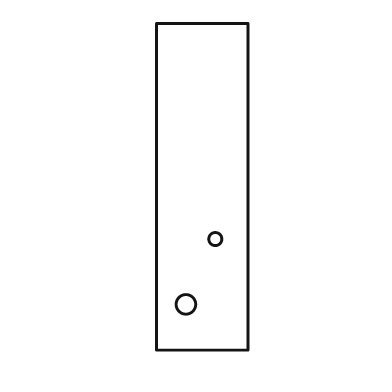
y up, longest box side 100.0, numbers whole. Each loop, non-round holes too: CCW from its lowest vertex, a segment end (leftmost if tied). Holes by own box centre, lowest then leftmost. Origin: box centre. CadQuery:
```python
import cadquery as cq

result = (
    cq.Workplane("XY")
    .moveTo(-14.0, -50.0)
    .lineTo(14.0, -50.0)
    .lineTo(14.0, 50.0)
    .lineTo(-14.0, 50.0)
    .close()
    .moveTo(-5.0, -36.0)
    .circle(3.0)
    .moveTo(4.0, -16.0)
    .circle(2.0)
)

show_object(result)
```